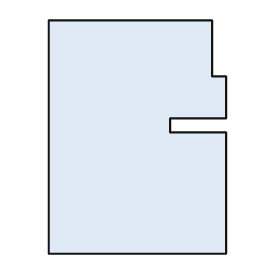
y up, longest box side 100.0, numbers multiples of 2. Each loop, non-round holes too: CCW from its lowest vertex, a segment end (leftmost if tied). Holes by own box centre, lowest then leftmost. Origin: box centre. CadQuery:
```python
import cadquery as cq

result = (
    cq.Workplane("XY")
    .moveTo(-38.0, -50.0)
    .lineTo(38.0, -50.0)
    .lineTo(38.0, 2.0)
    .lineTo(14.0, 2.0)
    .lineTo(14.0, 8.0)
    .lineTo(38.0, 8.0)
    .lineTo(38.0, 26.0)
    .lineTo(32.0, 26.0)
    .lineTo(32.0, 50.0)
    .lineTo(-38.0, 50.0)
    .close()
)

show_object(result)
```